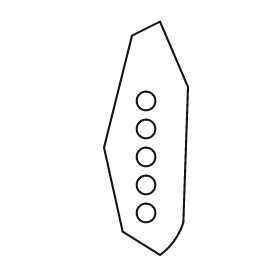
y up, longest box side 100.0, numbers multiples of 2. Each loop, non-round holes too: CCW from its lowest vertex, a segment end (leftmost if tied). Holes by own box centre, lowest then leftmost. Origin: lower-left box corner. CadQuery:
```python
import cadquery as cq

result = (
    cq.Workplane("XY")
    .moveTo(24.0, 0.0)
    .threePointArc((30.0, 6.0), (34.0, 14.0))
    .lineTo(36.0, 72.0)
    .lineTo(24.0, 100.0)
    .lineTo(12.0, 94.0)
    .lineTo(0.0, 46.0)
    .lineTo(8.0, 10.0)
    .close()
    .moveTo(18.0, 18.0)
    .circle(4.0)
    .moveTo(18.0, 30.0)
    .circle(4.0)
    .moveTo(18.0, 42.0)
    .circle(4.0)
    .moveTo(18.0, 54.0)
    .circle(4.0)
    .moveTo(18.0, 66.0)
    .circle(4.0)
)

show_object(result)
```